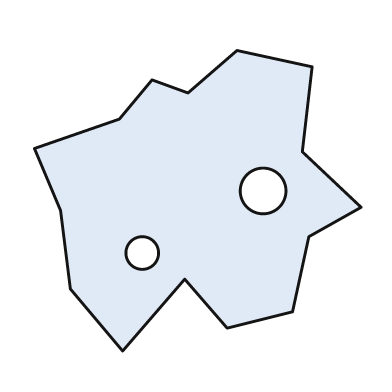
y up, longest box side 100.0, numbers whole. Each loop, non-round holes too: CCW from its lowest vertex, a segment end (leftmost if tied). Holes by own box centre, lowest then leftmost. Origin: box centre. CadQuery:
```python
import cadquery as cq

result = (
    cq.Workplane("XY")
    .moveTo(-23.0, -46.0)
    .lineTo(-4.0, -24.0)
    .lineTo(9.0, -39.0)
    .lineTo(29.0, -34.0)
    .lineTo(34.0, -11.0)
    .lineTo(50.0, -2.0)
    .lineTo(32.0, 15.0)
    .lineTo(35.0, 41.0)
    .lineTo(12.0, 46.0)
    .lineTo(-3.0, 33.0)
    .lineTo(-14.0, 37.0)
    .lineTo(-24.0, 25.0)
    .lineTo(-50.0, 16.0)
    .lineTo(-42.0, -3.0)
    .lineTo(-39.0, -27.0)
    .close()
    .moveTo(-17.0, -16.0)
    .circle(5.0)
    .moveTo(20.0, 3.0)
    .circle(7.0)
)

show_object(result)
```